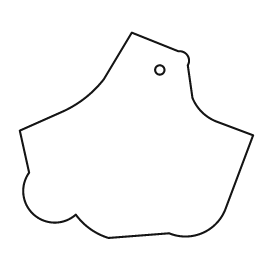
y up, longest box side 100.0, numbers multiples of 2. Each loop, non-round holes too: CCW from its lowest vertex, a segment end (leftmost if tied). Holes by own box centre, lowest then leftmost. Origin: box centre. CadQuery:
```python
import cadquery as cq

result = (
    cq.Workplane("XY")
    .moveTo(-12.0, -44.0)
    .lineTo(14.0, -42.0)
    .threePointArc((28.0, -42.0), (38.0, -32.0))
    .lineTo(50.0, 0.0)
    .lineTo(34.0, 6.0)
    .threePointArc((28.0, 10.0), (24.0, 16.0))
    .lineTo(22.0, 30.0)
    .threePointArc((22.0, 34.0), (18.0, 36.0))
    .lineTo(-2.0, 44.0)
    .lineTo(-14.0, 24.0)
    .threePointArc((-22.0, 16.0), (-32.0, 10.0))
    .lineTo(-50.0, 2.0)
    .lineTo(-46.0, -16.0)
    .threePointArc((-44.0, -34.0), (-26.0, -34.0))
    .threePointArc((-20.0, -40.0), (-12.0, -44.0))
    .close()
    .moveTo(10.0, 28.0)
    .circle(2.0)
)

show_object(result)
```